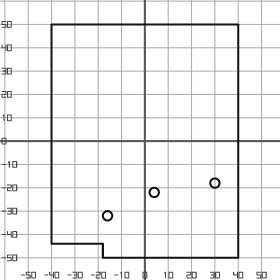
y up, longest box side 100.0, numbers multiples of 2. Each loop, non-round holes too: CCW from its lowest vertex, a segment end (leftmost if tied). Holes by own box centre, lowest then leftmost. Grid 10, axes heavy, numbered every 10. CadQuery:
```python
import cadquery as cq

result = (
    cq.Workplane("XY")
    .moveTo(-18.0, -50.0)
    .lineTo(40.0, -50.0)
    .lineTo(40.0, 50.0)
    .lineTo(-40.0, 50.0)
    .lineTo(-40.0, -44.0)
    .lineTo(-18.0, -44.0)
    .close()
    .moveTo(-16.0, -32.0)
    .circle(2.0)
    .moveTo(4.0, -22.0)
    .circle(2.0)
    .moveTo(30.0, -18.0)
    .circle(2.0)
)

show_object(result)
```